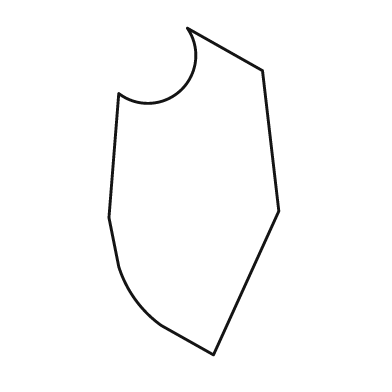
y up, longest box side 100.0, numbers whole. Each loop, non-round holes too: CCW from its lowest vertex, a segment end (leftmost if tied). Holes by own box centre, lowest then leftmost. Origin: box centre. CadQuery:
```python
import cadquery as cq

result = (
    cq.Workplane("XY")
    .moveTo(6.0, -50.0)
    .lineTo(26.0, -6.0)
    .lineTo(21.0, 37.0)
    .lineTo(-2.0, 50.0)
    .threePointArc((-4.0, 31.0), (-23.0, 30.0))
    .lineTo(-26.0, -8.0)
    .lineTo(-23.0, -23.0)
    .threePointArc((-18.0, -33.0), (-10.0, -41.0))
    .close()
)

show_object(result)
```